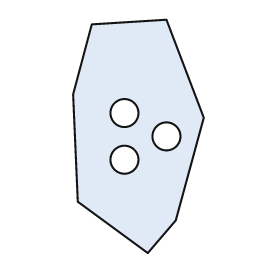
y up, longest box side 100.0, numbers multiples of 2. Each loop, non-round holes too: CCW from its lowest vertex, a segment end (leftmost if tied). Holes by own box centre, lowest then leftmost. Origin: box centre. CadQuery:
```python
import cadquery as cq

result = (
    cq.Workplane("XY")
    .moveTo(4.0, -50.0)
    .lineTo(16.0, -36.0)
    .lineTo(28.0, 8.0)
    .lineTo(12.0, 50.0)
    .lineTo(-20.0, 48.0)
    .lineTo(-28.0, 18.0)
    .lineTo(-26.0, -28.0)
    .close()
    .moveTo(-6.0, -10.0)
    .circle(6.0)
    .moveTo(12.0, 0.0)
    .circle(6.0)
    .moveTo(-6.0, 10.0)
    .circle(6.0)
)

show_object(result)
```